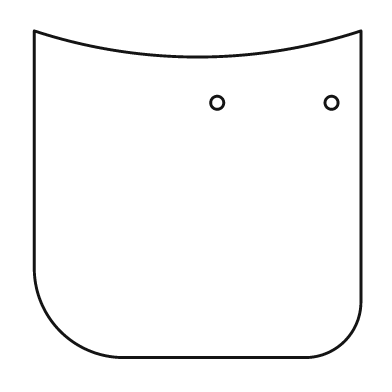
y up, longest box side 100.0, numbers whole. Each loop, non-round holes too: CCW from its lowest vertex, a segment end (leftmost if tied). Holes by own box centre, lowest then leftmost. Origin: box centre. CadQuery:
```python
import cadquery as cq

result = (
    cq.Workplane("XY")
    .moveTo(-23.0, -50.0)
    .lineTo(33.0, -50.0)
    .threePointArc((45.0, -45.0), (50.0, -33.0))
    .lineTo(50.0, 50.0)
    .threePointArc((0.0, 42.0), (-50.0, 50.0))
    .lineTo(-50.0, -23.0)
    .threePointArc((-42.0, -42.0), (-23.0, -50.0))
    .close()
    .moveTo(6.0, 28.0)
    .circle(2.0)
    .moveTo(41.0, 28.0)
    .circle(2.0)
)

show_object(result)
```